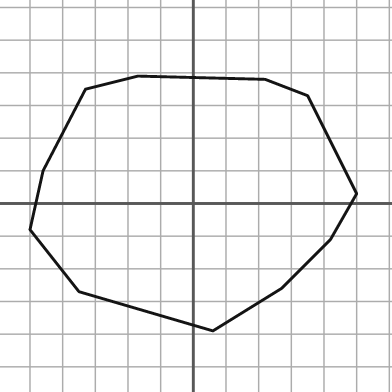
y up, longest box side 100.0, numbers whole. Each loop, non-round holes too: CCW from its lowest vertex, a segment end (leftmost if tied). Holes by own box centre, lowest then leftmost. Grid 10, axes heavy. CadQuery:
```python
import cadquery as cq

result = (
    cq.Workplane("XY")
    .moveTo(6.0, -39.0)
    .lineTo(27.0, -26.0)
    .lineTo(42.0, -11.0)
    .lineTo(50.0, 3.0)
    .lineTo(35.0, 33.0)
    .lineTo(22.0, 38.0)
    .lineTo(-17.0, 39.0)
    .lineTo(-33.0, 35.0)
    .lineTo(-46.0, 10.0)
    .lineTo(-50.0, -8.0)
    .lineTo(-35.0, -27.0)
    .close()
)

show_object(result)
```